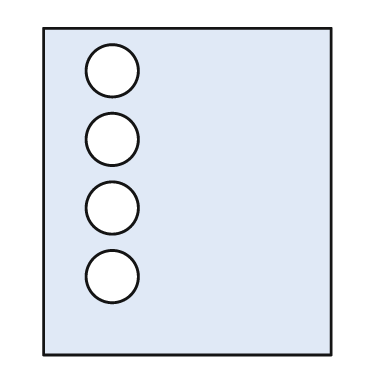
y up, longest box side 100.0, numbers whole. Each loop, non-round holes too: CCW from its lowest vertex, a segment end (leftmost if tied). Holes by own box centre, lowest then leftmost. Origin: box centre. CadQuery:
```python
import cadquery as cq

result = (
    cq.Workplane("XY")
    .moveTo(-44.0, -50.0)
    .lineTo(44.0, -50.0)
    .lineTo(44.0, 50.0)
    .lineTo(-44.0, 50.0)
    .close()
    .moveTo(-23.0, -26.0)
    .circle(8.0)
    .moveTo(-23.0, -5.0)
    .circle(8.0)
    .moveTo(-23.0, 16.0)
    .circle(8.0)
    .moveTo(-23.0, 37.0)
    .circle(8.0)
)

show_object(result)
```